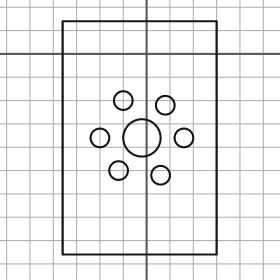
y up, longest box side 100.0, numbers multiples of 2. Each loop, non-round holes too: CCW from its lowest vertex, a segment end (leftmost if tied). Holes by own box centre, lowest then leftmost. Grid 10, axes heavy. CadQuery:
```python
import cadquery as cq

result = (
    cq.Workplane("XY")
    .moveTo(-36.0, -86.0)
    .lineTo(30.0, -86.0)
    .lineTo(30.0, 14.0)
    .lineTo(-36.0, 14.0)
    .close()
    .moveTo(6.0, -52.0)
    .circle(4.0)
    .moveTo(-12.0, -50.0)
    .circle(4.0)
    .moveTo(-20.0, -36.0)
    .circle(4.0)
    .moveTo(-2.0, -36.0)
    .circle(8.0)
    .moveTo(16.0, -36.0)
    .circle(4.0)
    .moveTo(8.0, -22.0)
    .circle(4.0)
    .moveTo(-10.0, -20.0)
    .circle(4.0)
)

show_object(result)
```